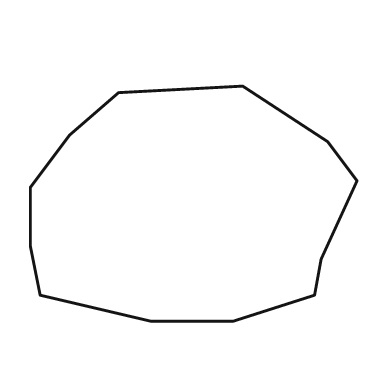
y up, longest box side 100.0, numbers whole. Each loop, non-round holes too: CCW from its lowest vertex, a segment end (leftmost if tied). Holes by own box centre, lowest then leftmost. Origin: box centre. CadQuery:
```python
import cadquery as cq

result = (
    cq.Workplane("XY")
    .moveTo(-13.0, -36.0)
    .lineTo(12.0, -36.0)
    .lineTo(37.0, -28.0)
    .lineTo(39.0, -17.0)
    .lineTo(50.0, 7.0)
    .lineTo(41.0, 19.0)
    .lineTo(15.0, 36.0)
    .lineTo(-23.0, 34.0)
    .lineTo(-38.0, 21.0)
    .lineTo(-50.0, 5.0)
    .lineTo(-50.0, -13.0)
    .lineTo(-47.0, -28.0)
    .close()
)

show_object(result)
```